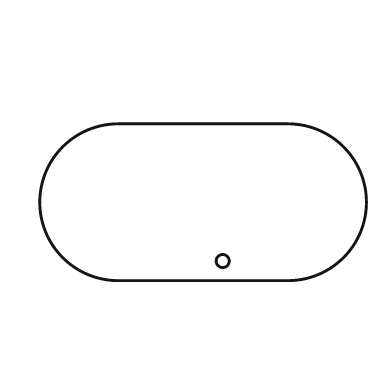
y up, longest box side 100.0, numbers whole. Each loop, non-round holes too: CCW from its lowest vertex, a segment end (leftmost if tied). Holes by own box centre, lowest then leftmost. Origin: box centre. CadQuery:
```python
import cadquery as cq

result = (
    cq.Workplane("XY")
    .moveTo(-26.0, -24.0)
    .lineTo(26.0, -24.0)
    .threePointArc((50.0, 0.0), (26.0, 24.0))
    .lineTo(-26.0, 24.0)
    .threePointArc((-50.0, 0.0), (-26.0, -24.0))
    .close()
    .moveTo(6.0, -18.0)
    .circle(2.0)
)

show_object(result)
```